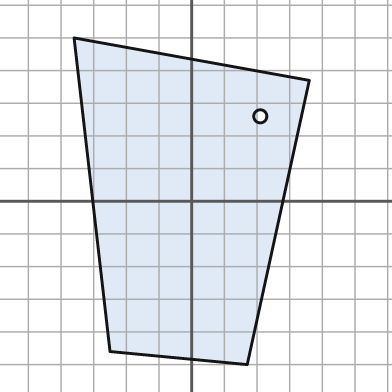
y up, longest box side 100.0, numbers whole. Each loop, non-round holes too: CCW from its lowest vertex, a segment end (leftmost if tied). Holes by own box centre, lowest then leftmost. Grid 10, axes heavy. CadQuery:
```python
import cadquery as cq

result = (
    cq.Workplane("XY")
    .moveTo(17.0, -50.0)
    .lineTo(36.0, 37.0)
    .lineTo(-36.0, 50.0)
    .lineTo(-25.0, -46.0)
    .close()
    .moveTo(21.0, 26.0)
    .circle(2.0)
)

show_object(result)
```